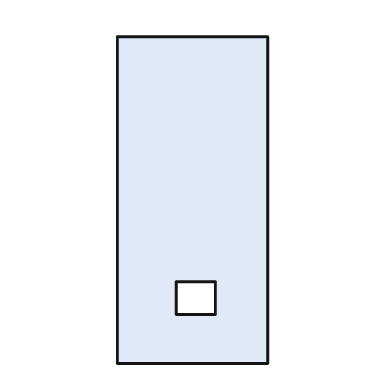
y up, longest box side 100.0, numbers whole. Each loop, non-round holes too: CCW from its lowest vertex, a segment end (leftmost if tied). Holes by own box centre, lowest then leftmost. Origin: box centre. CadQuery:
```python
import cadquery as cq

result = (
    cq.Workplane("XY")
    .moveTo(-23.0, -50.0)
    .lineTo(23.0, -50.0)
    .lineTo(23.0, 50.0)
    .lineTo(-23.0, 50.0)
    .close()
    .moveTo(-5.0, -35.0)
    .lineTo(7.0, -35.0)
    .lineTo(7.0, -25.0)
    .lineTo(-5.0, -25.0)
    .close()
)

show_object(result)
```